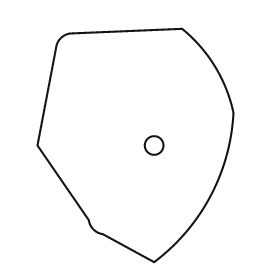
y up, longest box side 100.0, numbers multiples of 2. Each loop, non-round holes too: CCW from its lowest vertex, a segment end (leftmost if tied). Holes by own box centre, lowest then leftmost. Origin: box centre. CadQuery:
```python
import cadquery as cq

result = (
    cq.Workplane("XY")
    .moveTo(8.0, -50.0)
    .threePointArc((32.0, -22.0), (42.0, 14.0))
    .threePointArc((34.0, 34.0), (20.0, 50.0))
    .lineTo(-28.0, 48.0)
    .threePointArc((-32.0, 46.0), (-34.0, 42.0))
    .lineTo(-42.0, 0.0)
    .lineTo(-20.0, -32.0)
    .threePointArc((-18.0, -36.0), (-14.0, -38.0))
    .close()
    .moveTo(8.0, 0.0)
    .circle(4.0)
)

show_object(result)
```